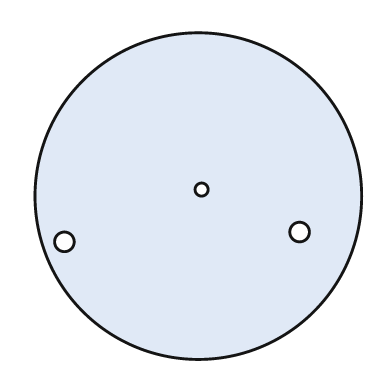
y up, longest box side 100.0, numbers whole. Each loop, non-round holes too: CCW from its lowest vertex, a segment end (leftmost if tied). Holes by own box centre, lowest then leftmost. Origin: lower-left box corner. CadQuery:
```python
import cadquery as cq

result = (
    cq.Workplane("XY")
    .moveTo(50.0, 50.0)
    .circle(50.0)
    .moveTo(9.0, 36.0)
    .circle(3.0)
    .moveTo(81.0, 39.0)
    .circle(3.0)
    .moveTo(51.0, 52.0)
    .circle(2.0)
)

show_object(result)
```